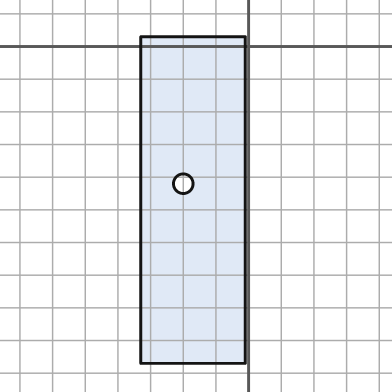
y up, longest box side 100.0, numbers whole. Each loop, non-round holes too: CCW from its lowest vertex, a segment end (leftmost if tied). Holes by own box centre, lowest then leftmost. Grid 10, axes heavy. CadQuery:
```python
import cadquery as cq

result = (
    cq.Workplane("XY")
    .moveTo(-33.0, -97.0)
    .lineTo(-1.0, -97.0)
    .lineTo(-1.0, 3.0)
    .lineTo(-33.0, 3.0)
    .close()
    .moveTo(-20.0, -42.0)
    .circle(3.0)
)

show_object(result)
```